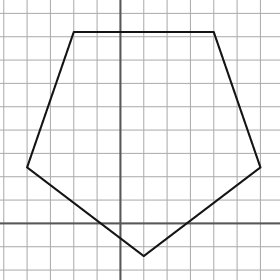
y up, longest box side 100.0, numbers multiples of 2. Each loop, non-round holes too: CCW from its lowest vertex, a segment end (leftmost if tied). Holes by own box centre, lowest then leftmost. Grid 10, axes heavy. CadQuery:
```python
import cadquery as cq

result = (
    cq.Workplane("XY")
    .moveTo(10.0, -14.0)
    .lineTo(60.0, 24.0)
    .lineTo(40.0, 82.0)
    .lineTo(-20.0, 82.0)
    .lineTo(-40.0, 24.0)
    .close()
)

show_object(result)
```